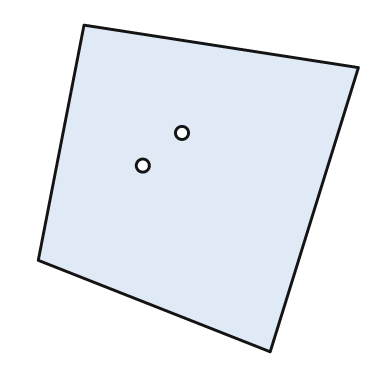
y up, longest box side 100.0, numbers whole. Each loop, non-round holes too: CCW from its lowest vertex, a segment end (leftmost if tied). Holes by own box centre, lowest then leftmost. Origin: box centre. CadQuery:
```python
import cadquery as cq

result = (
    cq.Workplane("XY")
    .moveTo(22.0, -50.0)
    .lineTo(49.0, 37.0)
    .lineTo(-35.0, 50.0)
    .lineTo(-49.0, -22.0)
    .close()
    .moveTo(-17.0, 7.0)
    .circle(2.0)
    .moveTo(-5.0, 17.0)
    .circle(2.0)
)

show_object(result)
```